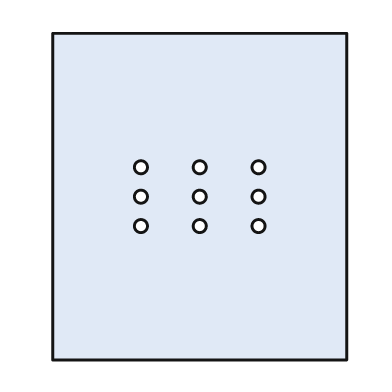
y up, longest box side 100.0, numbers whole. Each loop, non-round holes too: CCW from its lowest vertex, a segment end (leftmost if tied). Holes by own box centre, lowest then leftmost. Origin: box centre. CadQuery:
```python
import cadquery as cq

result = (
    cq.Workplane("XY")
    .moveTo(-45.0, -50.0)
    .lineTo(45.0, -50.0)
    .lineTo(45.0, 50.0)
    .lineTo(-45.0, 50.0)
    .close()
    .moveTo(-18.0, -9.0)
    .circle(2.0)
    .moveTo(0.0, -9.0)
    .circle(2.0)
    .moveTo(18.0, -9.0)
    .circle(2.0)
    .moveTo(-18.0, 0.0)
    .circle(2.0)
    .moveTo(0.0, 0.0)
    .circle(2.0)
    .moveTo(18.0, 0.0)
    .circle(2.0)
    .moveTo(-18.0, 9.0)
    .circle(2.0)
    .moveTo(0.0, 9.0)
    .circle(2.0)
    .moveTo(18.0, 9.0)
    .circle(2.0)
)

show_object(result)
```